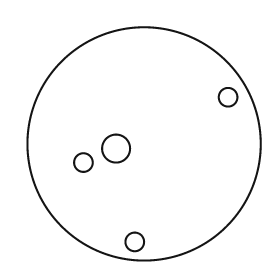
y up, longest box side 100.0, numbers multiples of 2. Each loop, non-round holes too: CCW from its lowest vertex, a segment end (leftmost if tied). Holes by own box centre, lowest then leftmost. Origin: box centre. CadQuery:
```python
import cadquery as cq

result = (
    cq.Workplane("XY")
    .moveTo(0.0, 0.0)
    .circle(50.0)
    .moveTo(-4.0, -42.0)
    .circle(4.0)
    .moveTo(-26.0, -8.0)
    .circle(4.0)
    .moveTo(-12.0, -2.0)
    .circle(6.0)
    .moveTo(36.0, 20.0)
    .circle(4.0)
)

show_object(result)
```